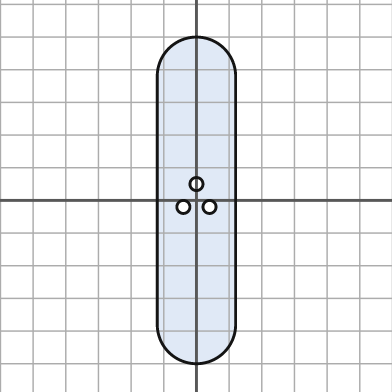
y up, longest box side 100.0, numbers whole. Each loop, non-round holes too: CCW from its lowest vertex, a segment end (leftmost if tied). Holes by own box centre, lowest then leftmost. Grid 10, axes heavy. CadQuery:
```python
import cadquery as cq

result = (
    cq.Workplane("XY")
    .moveTo(-12.0, -38.0)
    .threePointArc((0.0, -50.0), (12.0, -38.0))
    .lineTo(12.0, 38.0)
    .threePointArc((0.0, 50.0), (-12.0, 38.0))
    .close()
    .moveTo(-4.0, -2.0)
    .circle(2.0)
    .moveTo(4.0, -2.0)
    .circle(2.0)
    .moveTo(0.0, 5.0)
    .circle(2.0)
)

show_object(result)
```